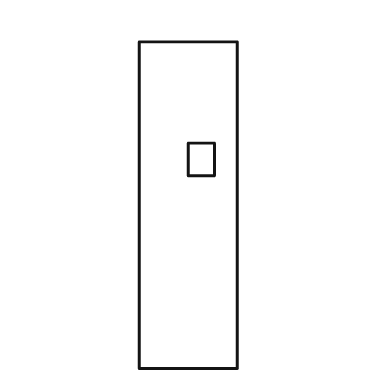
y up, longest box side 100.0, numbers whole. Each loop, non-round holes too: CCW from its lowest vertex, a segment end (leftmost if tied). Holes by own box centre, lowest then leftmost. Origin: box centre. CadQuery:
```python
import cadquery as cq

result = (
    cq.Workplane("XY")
    .moveTo(-15.0, -50.0)
    .lineTo(15.0, -50.0)
    .lineTo(15.0, 50.0)
    .lineTo(-15.0, 50.0)
    .close()
    .moveTo(0.0, 9.0)
    .lineTo(8.0, 9.0)
    .lineTo(8.0, 19.0)
    .lineTo(0.0, 19.0)
    .close()
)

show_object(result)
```